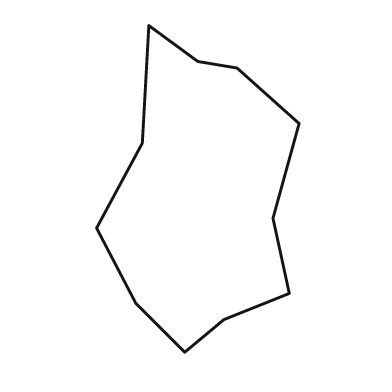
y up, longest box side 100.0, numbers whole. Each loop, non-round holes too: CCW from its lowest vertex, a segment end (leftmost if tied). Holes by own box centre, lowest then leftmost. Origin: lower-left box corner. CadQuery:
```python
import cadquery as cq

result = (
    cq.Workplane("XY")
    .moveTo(27.0, 0.0)
    .lineTo(39.0, 10.0)
    .lineTo(59.0, 18.0)
    .lineTo(54.0, 41.0)
    .lineTo(62.0, 70.0)
    .lineTo(43.0, 87.0)
    .lineTo(31.0, 89.0)
    .lineTo(16.0, 100.0)
    .lineTo(14.0, 64.0)
    .lineTo(0.0, 38.0)
    .lineTo(12.0, 15.0)
    .close()
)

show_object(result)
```